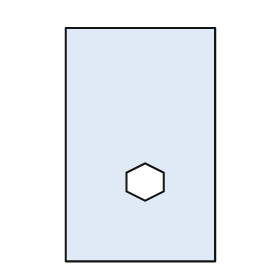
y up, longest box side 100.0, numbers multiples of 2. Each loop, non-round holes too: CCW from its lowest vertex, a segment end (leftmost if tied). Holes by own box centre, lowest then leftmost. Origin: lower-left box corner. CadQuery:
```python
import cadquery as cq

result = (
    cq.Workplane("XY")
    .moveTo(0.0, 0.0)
    .lineTo(64.0, 0.0)
    .lineTo(64.0, 100.0)
    .lineTo(0.0, 100.0)
    .close()
    .moveTo(34.0, 26.0)
    .lineTo(42.0, 30.0)
    .lineTo(42.0, 38.0)
    .lineTo(34.0, 42.0)
    .lineTo(26.0, 38.0)
    .lineTo(26.0, 30.0)
    .close()
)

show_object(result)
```